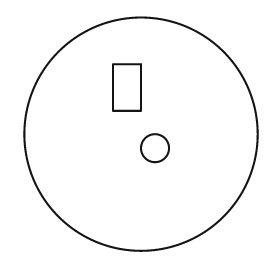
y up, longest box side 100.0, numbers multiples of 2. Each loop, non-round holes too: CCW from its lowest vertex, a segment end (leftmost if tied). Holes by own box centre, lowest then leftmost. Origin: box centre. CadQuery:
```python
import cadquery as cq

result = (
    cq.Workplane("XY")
    .moveTo(0.0, 0.0)
    .circle(50.0)
    .moveTo(6.0, -6.0)
    .circle(6.0)
    .moveTo(-12.0, 10.0)
    .lineTo(0.0, 10.0)
    .lineTo(0.0, 30.0)
    .lineTo(-12.0, 30.0)
    .close()
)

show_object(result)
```